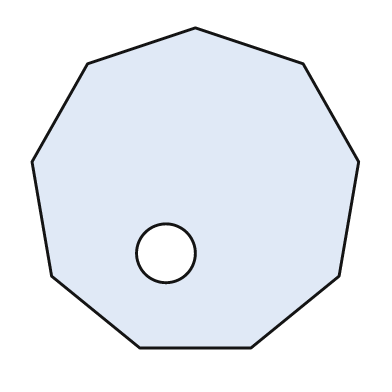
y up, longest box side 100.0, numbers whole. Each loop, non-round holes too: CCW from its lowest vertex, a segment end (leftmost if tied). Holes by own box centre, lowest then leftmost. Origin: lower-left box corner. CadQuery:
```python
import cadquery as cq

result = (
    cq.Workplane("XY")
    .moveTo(33.0, 0.0)
    .lineTo(67.0, 0.0)
    .lineTo(94.0, 22.0)
    .lineTo(100.0, 57.0)
    .lineTo(83.0, 87.0)
    .lineTo(50.0, 98.0)
    .lineTo(17.0, 87.0)
    .lineTo(0.0, 57.0)
    .lineTo(6.0, 22.0)
    .close()
    .moveTo(41.0, 29.0)
    .circle(9.0)
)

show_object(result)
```